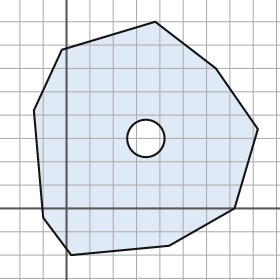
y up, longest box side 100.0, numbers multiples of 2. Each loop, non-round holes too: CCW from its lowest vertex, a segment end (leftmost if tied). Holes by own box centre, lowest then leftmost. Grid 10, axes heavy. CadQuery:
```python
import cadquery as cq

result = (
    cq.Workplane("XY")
    .moveTo(2.0, -20.0)
    .lineTo(44.0, -16.0)
    .lineTo(72.0, 0.0)
    .lineTo(82.0, 34.0)
    .lineTo(64.0, 60.0)
    .lineTo(38.0, 80.0)
    .lineTo(-2.0, 68.0)
    .lineTo(-14.0, 42.0)
    .lineTo(-10.0, -4.0)
    .close()
    .moveTo(34.0, 30.0)
    .circle(8.0)
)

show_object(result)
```